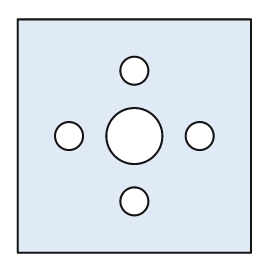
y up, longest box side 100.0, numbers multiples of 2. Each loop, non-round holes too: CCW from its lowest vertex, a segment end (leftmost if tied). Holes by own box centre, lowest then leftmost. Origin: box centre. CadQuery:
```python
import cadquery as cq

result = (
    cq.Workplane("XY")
    .moveTo(-50.0, -50.0)
    .lineTo(50.0, -50.0)
    .lineTo(50.0, 50.0)
    .lineTo(-50.0, 50.0)
    .close()
    .moveTo(0.0, -28.0)
    .circle(6.0)
    .moveTo(-28.0, 0.0)
    .circle(6.0)
    .moveTo(0.0, 0.0)
    .circle(12.0)
    .moveTo(28.0, 0.0)
    .circle(6.0)
    .moveTo(0.0, 28.0)
    .circle(6.0)
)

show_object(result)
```